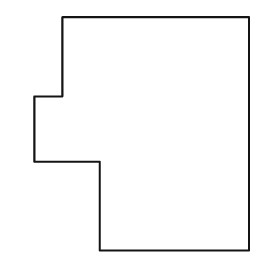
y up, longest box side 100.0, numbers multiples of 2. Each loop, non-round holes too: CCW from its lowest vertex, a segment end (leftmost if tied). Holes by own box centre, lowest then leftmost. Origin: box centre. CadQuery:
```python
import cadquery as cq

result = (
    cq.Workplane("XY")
    .moveTo(-18.0, -50.0)
    .lineTo(46.0, -50.0)
    .lineTo(46.0, 50.0)
    .lineTo(-34.0, 50.0)
    .lineTo(-34.0, 16.0)
    .lineTo(-46.0, 16.0)
    .lineTo(-46.0, -12.0)
    .lineTo(-18.0, -12.0)
    .close()
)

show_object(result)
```